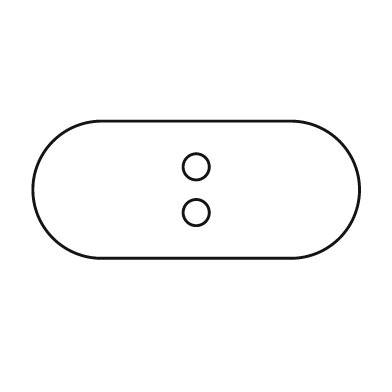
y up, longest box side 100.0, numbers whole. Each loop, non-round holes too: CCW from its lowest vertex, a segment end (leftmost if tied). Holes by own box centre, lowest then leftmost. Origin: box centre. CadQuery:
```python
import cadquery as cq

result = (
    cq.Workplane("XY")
    .moveTo(-29.0, -21.0)
    .lineTo(29.0, -21.0)
    .threePointArc((50.0, 0.0), (29.0, 21.0))
    .lineTo(-29.0, 21.0)
    .threePointArc((-50.0, 0.0), (-29.0, -21.0))
    .close()
    .moveTo(0.0, -7.0)
    .circle(4.0)
    .moveTo(0.0, 7.0)
    .circle(4.0)
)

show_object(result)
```